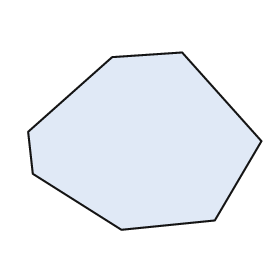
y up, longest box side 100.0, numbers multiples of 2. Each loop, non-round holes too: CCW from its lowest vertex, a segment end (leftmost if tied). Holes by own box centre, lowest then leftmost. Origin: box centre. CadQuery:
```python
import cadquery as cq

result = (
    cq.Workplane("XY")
    .moveTo(-10.0, -38.0)
    .lineTo(30.0, -34.0)
    .lineTo(50.0, 0.0)
    .lineTo(16.0, 38.0)
    .lineTo(-14.0, 36.0)
    .lineTo(-50.0, 4.0)
    .lineTo(-48.0, -14.0)
    .close()
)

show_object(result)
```